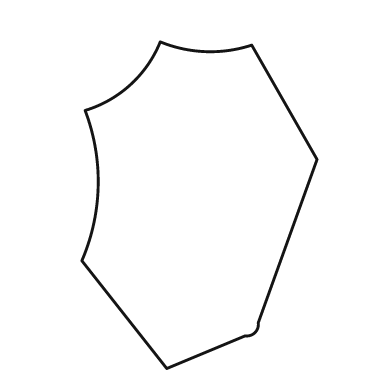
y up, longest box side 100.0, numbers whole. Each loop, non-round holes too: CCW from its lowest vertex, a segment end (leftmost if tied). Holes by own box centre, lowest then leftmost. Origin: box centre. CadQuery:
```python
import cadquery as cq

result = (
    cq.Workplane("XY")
    .moveTo(-10.0, -50.0)
    .lineTo(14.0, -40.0)
    .threePointArc((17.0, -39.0), (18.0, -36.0))
    .lineTo(36.0, 14.0)
    .lineTo(16.0, 49.0)
    .threePointArc((2.0, 47.0), (-12.0, 50.0))
    .threePointArc((-21.0, 37.0), (-35.0, 29.0))
    .threePointArc((-31.0, 6.0), (-36.0, -17.0))
    .close()
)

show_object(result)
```